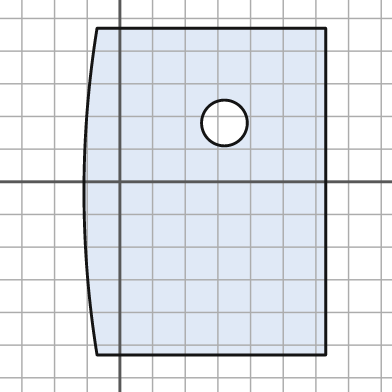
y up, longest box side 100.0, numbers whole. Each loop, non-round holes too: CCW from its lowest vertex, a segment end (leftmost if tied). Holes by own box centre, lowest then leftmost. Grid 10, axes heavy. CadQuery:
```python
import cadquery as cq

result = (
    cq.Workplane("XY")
    .moveTo(-7.0, -53.0)
    .lineTo(63.0, -53.0)
    .lineTo(63.0, 47.0)
    .lineTo(-7.0, 47.0)
    .threePointArc((-11.0, -3.0), (-7.0, -53.0))
    .close()
    .moveTo(32.0, 18.0)
    .circle(7.0)
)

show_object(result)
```